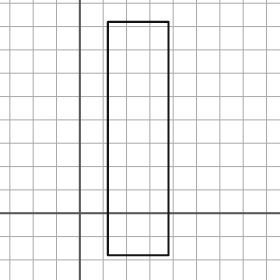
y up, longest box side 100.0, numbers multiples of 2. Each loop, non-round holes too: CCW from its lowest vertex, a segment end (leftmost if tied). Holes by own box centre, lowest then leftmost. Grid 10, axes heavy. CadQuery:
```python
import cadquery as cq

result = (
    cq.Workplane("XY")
    .moveTo(12.0, -18.0)
    .lineTo(38.0, -18.0)
    .lineTo(38.0, 82.0)
    .lineTo(12.0, 82.0)
    .close()
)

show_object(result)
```